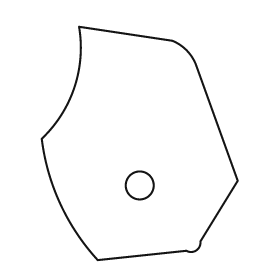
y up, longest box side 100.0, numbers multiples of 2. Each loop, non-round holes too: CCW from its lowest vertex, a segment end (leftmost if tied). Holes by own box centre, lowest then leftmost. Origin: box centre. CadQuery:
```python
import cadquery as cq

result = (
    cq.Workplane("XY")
    .moveTo(-18.0, -50.0)
    .lineTo(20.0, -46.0)
    .threePointArc((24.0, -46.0), (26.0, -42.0))
    .lineTo(42.0, -16.0)
    .lineTo(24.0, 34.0)
    .threePointArc((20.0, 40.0), (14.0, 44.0))
    .lineTo(-26.0, 50.0)
    .threePointArc((-28.0, 24.0), (-42.0, 2.0))
    .threePointArc((-34.0, -26.0), (-18.0, -50.0))
    .close()
    .moveTo(0.0, -18.0)
    .circle(6.0)
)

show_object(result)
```